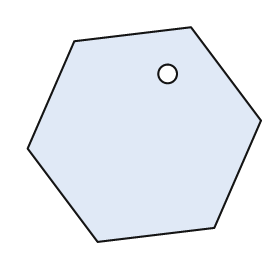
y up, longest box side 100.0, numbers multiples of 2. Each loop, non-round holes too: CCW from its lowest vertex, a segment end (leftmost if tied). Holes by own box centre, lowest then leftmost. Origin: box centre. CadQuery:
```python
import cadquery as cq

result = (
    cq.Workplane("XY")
    .moveTo(-20.0, -46.0)
    .lineTo(30.0, -40.0)
    .lineTo(50.0, 6.0)
    .lineTo(20.0, 46.0)
    .lineTo(-30.0, 40.0)
    .lineTo(-50.0, -6.0)
    .close()
    .moveTo(10.0, 26.0)
    .circle(4.0)
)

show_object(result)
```